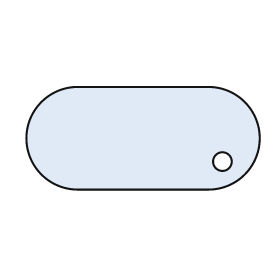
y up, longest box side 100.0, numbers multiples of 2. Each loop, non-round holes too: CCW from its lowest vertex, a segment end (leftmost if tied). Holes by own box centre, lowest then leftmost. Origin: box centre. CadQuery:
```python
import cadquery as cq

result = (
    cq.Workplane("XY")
    .moveTo(-28.0, -22.0)
    .lineTo(28.0, -22.0)
    .threePointArc((50.0, 0.0), (28.0, 22.0))
    .lineTo(-28.0, 22.0)
    .threePointArc((-50.0, 0.0), (-28.0, -22.0))
    .close()
    .moveTo(34.0, -10.0)
    .circle(4.0)
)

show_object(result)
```